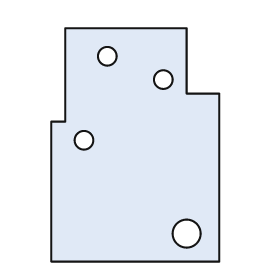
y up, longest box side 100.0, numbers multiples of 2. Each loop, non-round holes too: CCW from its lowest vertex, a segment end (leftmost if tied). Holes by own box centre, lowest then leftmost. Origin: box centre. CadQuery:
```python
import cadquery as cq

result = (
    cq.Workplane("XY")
    .moveTo(-36.0, -50.0)
    .lineTo(36.0, -50.0)
    .lineTo(36.0, 22.0)
    .lineTo(22.0, 22.0)
    .lineTo(22.0, 50.0)
    .lineTo(-30.0, 50.0)
    .lineTo(-30.0, 10.0)
    .lineTo(-36.0, 10.0)
    .close()
    .moveTo(22.0, -38.0)
    .circle(6.0)
    .moveTo(-22.0, 2.0)
    .circle(4.0)
    .moveTo(12.0, 28.0)
    .circle(4.0)
    .moveTo(-12.0, 38.0)
    .circle(4.0)
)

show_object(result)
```